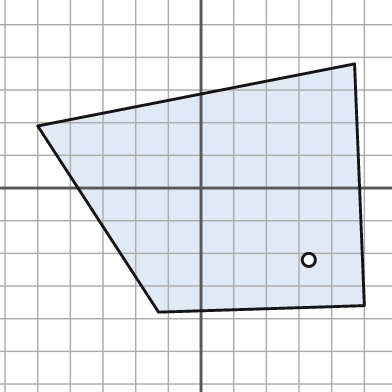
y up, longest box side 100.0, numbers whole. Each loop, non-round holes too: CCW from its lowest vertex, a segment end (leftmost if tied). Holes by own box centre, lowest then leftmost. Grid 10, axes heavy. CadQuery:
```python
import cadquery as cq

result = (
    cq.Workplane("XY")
    .moveTo(-13.0, -38.0)
    .lineTo(50.0, -36.0)
    .lineTo(47.0, 38.0)
    .lineTo(-50.0, 19.0)
    .close()
    .moveTo(33.0, -22.0)
    .circle(2.0)
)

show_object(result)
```